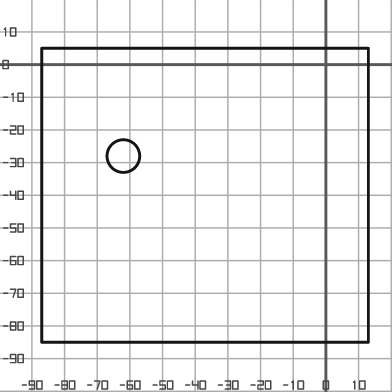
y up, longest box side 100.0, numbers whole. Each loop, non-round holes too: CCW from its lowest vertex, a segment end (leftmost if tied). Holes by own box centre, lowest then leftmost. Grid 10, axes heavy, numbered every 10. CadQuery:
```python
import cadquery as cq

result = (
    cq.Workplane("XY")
    .moveTo(-87.0, -85.0)
    .lineTo(13.0, -85.0)
    .lineTo(13.0, 5.0)
    .lineTo(-87.0, 5.0)
    .close()
    .moveTo(-62.0, -28.0)
    .circle(5.0)
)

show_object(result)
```